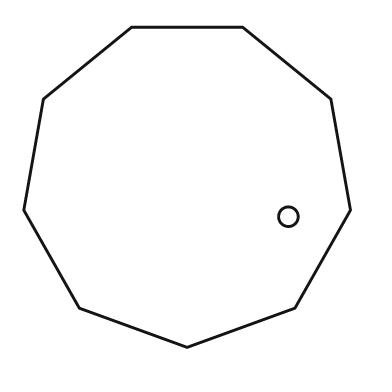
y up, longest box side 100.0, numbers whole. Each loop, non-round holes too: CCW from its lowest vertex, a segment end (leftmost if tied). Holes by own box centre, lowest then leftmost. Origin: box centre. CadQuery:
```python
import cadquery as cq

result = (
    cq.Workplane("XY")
    .moveTo(0.0, -49.0)
    .lineTo(33.0, -37.0)
    .lineTo(50.0, -7.0)
    .lineTo(44.0, 27.0)
    .lineTo(17.0, 49.0)
    .lineTo(-17.0, 49.0)
    .lineTo(-44.0, 27.0)
    .lineTo(-50.0, -7.0)
    .lineTo(-33.0, -37.0)
    .close()
    .moveTo(31.0, -9.0)
    .circle(3.0)
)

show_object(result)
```